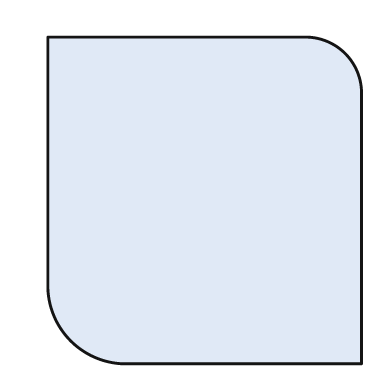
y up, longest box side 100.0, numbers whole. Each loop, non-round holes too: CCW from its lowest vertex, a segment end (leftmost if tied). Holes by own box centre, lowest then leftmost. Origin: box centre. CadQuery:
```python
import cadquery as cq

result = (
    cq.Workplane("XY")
    .moveTo(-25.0, -50.0)
    .lineTo(48.0, -50.0)
    .lineTo(48.0, 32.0)
    .threePointArc((43.0, 45.0), (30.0, 50.0))
    .lineTo(-48.0, 50.0)
    .lineTo(-48.0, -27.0)
    .threePointArc((-41.0, -43.0), (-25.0, -50.0))
    .close()
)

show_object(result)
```